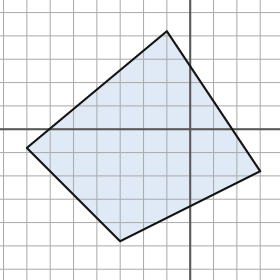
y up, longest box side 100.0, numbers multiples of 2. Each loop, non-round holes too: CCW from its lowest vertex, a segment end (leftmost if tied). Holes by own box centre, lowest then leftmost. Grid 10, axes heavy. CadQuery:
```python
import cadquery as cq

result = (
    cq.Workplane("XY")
    .moveTo(-30.0, -48.0)
    .lineTo(30.0, -18.0)
    .lineTo(-10.0, 42.0)
    .lineTo(-70.0, -8.0)
    .close()
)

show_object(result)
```